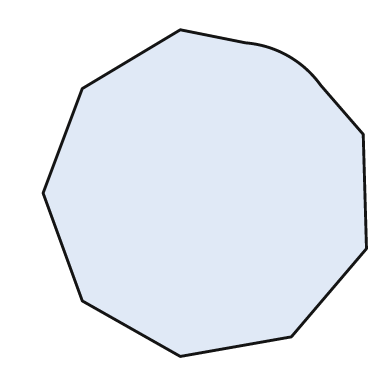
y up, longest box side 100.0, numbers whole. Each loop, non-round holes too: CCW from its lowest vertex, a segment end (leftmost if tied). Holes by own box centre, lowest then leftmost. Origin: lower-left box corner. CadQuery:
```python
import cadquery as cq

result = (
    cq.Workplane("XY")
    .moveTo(42.0, 0.0)
    .lineTo(76.0, 6.0)
    .lineTo(99.0, 33.0)
    .lineTo(98.0, 68.0)
    .lineTo(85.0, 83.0)
    .threePointArc((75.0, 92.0), (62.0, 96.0))
    .lineTo(42.0, 100.0)
    .lineTo(12.0, 82.0)
    .lineTo(0.0, 50.0)
    .lineTo(12.0, 17.0)
    .close()
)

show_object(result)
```